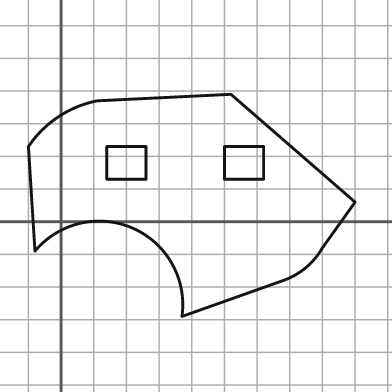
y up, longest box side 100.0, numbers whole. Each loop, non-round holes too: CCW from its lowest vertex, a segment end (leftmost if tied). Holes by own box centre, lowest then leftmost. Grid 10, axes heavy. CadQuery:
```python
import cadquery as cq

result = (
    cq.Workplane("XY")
    .moveTo(37.0, -29.0)
    .lineTo(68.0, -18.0)
    .threePointArc((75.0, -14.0), (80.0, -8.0))
    .lineTo(90.0, 6.0)
    .lineTo(52.0, 39.0)
    .lineTo(11.0, 37.0)
    .threePointArc((-1.0, 32.0), (-10.0, 23.0))
    .lineTo(-8.0, -9.0)
    .threePointArc((22.0, -2.0), (37.0, -29.0))
    .close()
    .moveTo(14.0, 13.0)
    .lineTo(26.0, 13.0)
    .lineTo(26.0, 23.0)
    .lineTo(14.0, 23.0)
    .close()
    .moveTo(50.0, 13.0)
    .lineTo(62.0, 13.0)
    .lineTo(62.0, 23.0)
    .lineTo(50.0, 23.0)
    .close()
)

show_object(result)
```